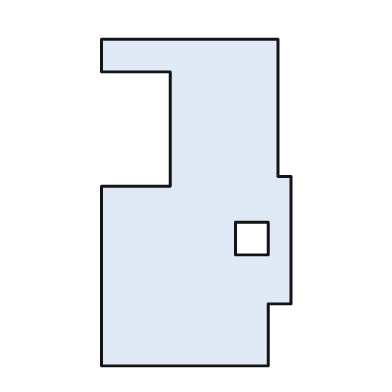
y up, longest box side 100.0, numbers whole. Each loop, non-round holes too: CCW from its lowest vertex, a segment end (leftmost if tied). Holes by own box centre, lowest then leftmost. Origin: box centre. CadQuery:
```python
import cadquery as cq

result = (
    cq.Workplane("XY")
    .moveTo(-29.0, -50.0)
    .lineTo(22.0, -50.0)
    .lineTo(22.0, -31.0)
    .lineTo(29.0, -31.0)
    .lineTo(29.0, 8.0)
    .lineTo(25.0, 8.0)
    .lineTo(25.0, 50.0)
    .lineTo(-29.0, 50.0)
    .lineTo(-29.0, 40.0)
    .lineTo(-8.0, 40.0)
    .lineTo(-8.0, 5.0)
    .lineTo(-29.0, 5.0)
    .close()
    .moveTo(12.0, -16.0)
    .lineTo(22.0, -16.0)
    .lineTo(22.0, -6.0)
    .lineTo(12.0, -6.0)
    .close()
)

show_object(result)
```